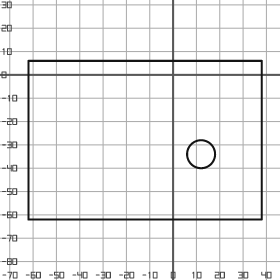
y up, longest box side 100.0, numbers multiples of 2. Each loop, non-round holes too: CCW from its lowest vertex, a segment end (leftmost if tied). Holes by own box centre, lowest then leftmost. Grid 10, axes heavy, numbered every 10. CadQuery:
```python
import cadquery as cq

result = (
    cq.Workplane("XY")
    .moveTo(-62.0, -62.0)
    .lineTo(38.0, -62.0)
    .lineTo(38.0, 6.0)
    .lineTo(-62.0, 6.0)
    .close()
    .moveTo(12.0, -34.0)
    .circle(6.0)
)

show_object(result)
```